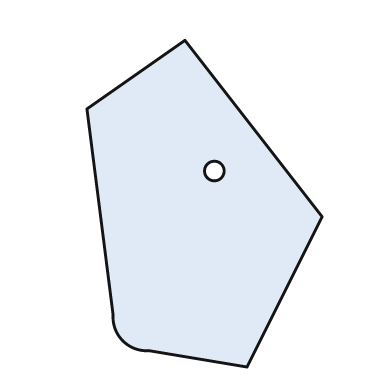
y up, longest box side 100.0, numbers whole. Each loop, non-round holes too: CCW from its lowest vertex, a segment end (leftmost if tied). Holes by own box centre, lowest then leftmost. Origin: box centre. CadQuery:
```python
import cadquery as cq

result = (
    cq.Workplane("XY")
    .moveTo(13.0, -50.0)
    .lineTo(36.0, -4.0)
    .lineTo(-6.0, 50.0)
    .lineTo(-36.0, 29.0)
    .lineTo(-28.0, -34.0)
    .threePointArc((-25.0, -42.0), (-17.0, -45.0))
    .close()
    .moveTo(3.0, 10.0)
    .circle(3.0)
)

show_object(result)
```